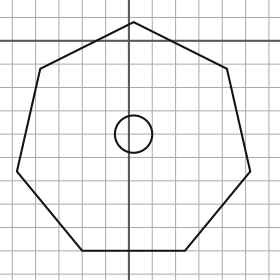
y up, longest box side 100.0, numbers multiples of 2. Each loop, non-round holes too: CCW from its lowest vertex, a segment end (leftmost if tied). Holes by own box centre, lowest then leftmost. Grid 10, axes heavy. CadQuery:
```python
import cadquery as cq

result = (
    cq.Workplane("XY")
    .moveTo(-20.0, -90.0)
    .lineTo(24.0, -90.0)
    .lineTo(52.0, -56.0)
    .lineTo(42.0, -12.0)
    .lineTo(2.0, 8.0)
    .lineTo(-38.0, -12.0)
    .lineTo(-48.0, -56.0)
    .close()
    .moveTo(2.0, -40.0)
    .circle(8.0)
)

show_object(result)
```